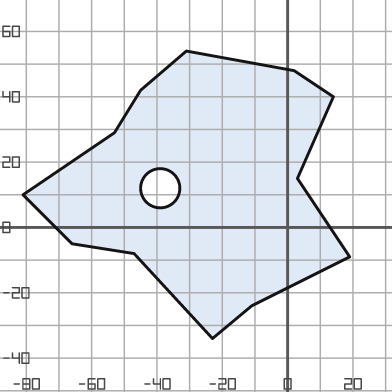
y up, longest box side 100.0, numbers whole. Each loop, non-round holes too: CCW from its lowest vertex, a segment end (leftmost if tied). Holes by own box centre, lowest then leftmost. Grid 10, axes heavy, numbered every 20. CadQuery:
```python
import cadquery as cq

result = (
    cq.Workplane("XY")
    .moveTo(-23.0, -34.0)
    .lineTo(-11.0, -24.0)
    .lineTo(19.0, -9.0)
    .lineTo(3.0, 15.0)
    .lineTo(14.0, 40.0)
    .lineTo(2.0, 48.0)
    .lineTo(-31.0, 54.0)
    .lineTo(-45.0, 42.0)
    .lineTo(-53.0, 29.0)
    .lineTo(-81.0, 10.0)
    .lineTo(-66.0, -5.0)
    .lineTo(-47.0, -8.0)
    .close()
    .moveTo(-39.0, 12.0)
    .circle(6.0)
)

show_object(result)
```